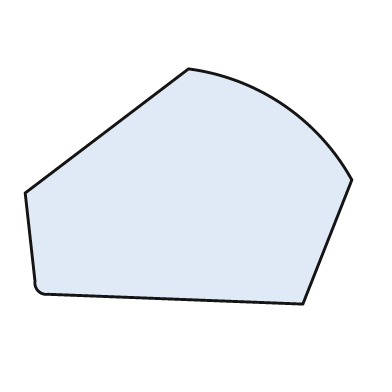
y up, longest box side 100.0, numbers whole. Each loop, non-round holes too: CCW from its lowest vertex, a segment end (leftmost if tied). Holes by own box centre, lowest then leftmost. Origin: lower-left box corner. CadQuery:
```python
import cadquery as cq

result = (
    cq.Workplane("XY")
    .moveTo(85.0, 0.0)
    .lineTo(100.0, 38.0)
    .threePointArc((79.0, 61.0), (50.0, 72.0))
    .lineTo(0.0, 34.0)
    .lineTo(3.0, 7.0)
    .threePointArc((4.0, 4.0), (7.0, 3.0))
    .close()
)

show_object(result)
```